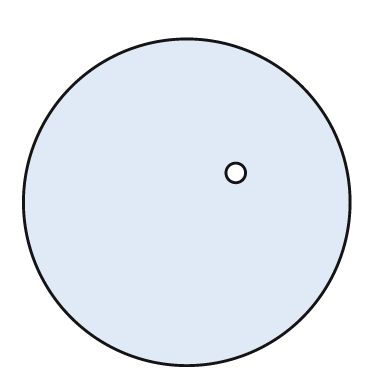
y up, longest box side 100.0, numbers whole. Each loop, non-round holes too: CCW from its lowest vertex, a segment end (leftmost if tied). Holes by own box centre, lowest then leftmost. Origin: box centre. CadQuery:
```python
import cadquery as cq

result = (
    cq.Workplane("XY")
    .moveTo(0.0, 0.0)
    .circle(50.0)
    .moveTo(15.0, 9.0)
    .circle(3.0)
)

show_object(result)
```